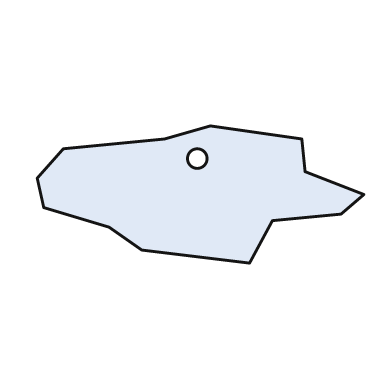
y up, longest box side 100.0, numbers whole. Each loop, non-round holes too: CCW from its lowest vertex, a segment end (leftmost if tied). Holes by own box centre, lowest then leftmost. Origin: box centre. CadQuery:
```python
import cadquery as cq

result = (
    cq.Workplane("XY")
    .moveTo(15.0, -21.0)
    .lineTo(22.0, -8.0)
    .lineTo(43.0, -6.0)
    .lineTo(50.0, 0.0)
    .lineTo(32.0, 7.0)
    .lineTo(31.0, 17.0)
    .lineTo(3.0, 21.0)
    .lineTo(-11.0, 17.0)
    .lineTo(-42.0, 14.0)
    .lineTo(-50.0, 5.0)
    .lineTo(-48.0, -4.0)
    .lineTo(-28.0, -10.0)
    .lineTo(-18.0, -17.0)
    .close()
    .moveTo(-1.0, 11.0)
    .circle(3.0)
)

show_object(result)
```